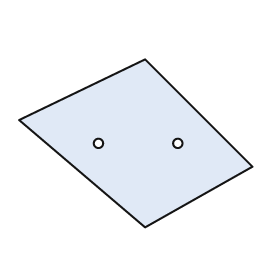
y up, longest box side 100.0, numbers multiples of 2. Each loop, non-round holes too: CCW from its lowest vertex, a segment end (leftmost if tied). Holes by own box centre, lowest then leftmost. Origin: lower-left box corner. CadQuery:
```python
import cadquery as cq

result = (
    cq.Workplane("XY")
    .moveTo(54.0, 0.0)
    .lineTo(100.0, 26.0)
    .lineTo(54.0, 72.0)
    .lineTo(0.0, 46.0)
    .close()
    .moveTo(34.0, 36.0)
    .circle(2.0)
    .moveTo(68.0, 36.0)
    .circle(2.0)
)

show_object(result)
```